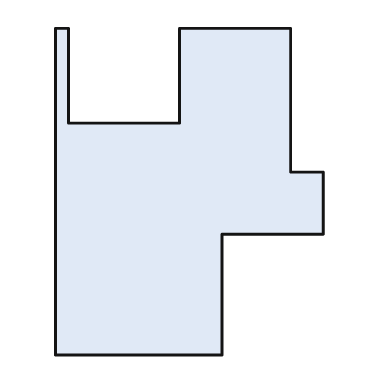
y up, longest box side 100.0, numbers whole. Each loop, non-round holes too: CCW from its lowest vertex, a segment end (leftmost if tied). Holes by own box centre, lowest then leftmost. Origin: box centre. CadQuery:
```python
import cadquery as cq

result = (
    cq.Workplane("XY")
    .moveTo(-41.0, -50.0)
    .lineTo(10.0, -50.0)
    .lineTo(10.0, -13.0)
    .lineTo(41.0, -13.0)
    .lineTo(41.0, 6.0)
    .lineTo(31.0, 6.0)
    .lineTo(31.0, 50.0)
    .lineTo(-3.0, 50.0)
    .lineTo(-3.0, 21.0)
    .lineTo(-37.0, 21.0)
    .lineTo(-37.0, 50.0)
    .lineTo(-41.0, 50.0)
    .close()
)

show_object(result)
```